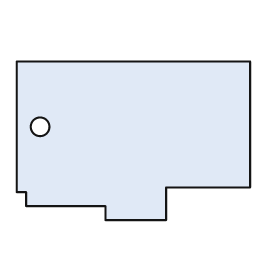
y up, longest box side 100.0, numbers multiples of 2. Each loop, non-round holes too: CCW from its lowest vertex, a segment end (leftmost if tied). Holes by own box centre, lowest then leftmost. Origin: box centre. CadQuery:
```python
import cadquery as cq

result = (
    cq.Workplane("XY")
    .moveTo(-12.0, -34.0)
    .lineTo(14.0, -34.0)
    .lineTo(14.0, -20.0)
    .lineTo(50.0, -20.0)
    .lineTo(50.0, 34.0)
    .lineTo(-50.0, 34.0)
    .lineTo(-50.0, -22.0)
    .lineTo(-46.0, -22.0)
    .lineTo(-46.0, -28.0)
    .lineTo(-12.0, -28.0)
    .close()
    .moveTo(-40.0, 6.0)
    .circle(4.0)
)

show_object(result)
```